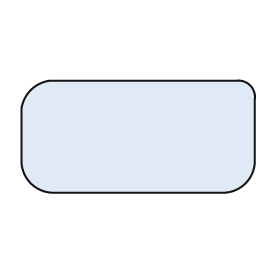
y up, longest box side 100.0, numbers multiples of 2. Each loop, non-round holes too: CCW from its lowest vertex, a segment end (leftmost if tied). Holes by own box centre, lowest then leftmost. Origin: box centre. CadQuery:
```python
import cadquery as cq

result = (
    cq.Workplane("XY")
    .moveTo(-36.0, -24.0)
    .lineTo(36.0, -24.0)
    .threePointArc((46.0, -20.0), (50.0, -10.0))
    .lineTo(50.0, 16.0)
    .threePointArc((48.0, 22.0), (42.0, 24.0))
    .lineTo(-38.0, 24.0)
    .threePointArc((-46.0, 20.0), (-50.0, 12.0))
    .lineTo(-50.0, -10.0)
    .threePointArc((-46.0, -20.0), (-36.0, -24.0))
    .close()
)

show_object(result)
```